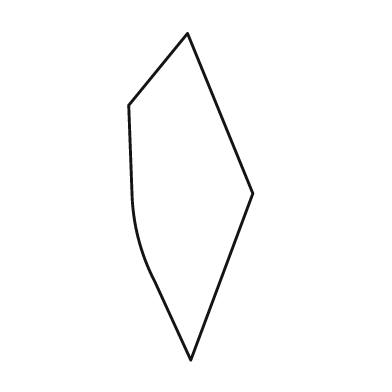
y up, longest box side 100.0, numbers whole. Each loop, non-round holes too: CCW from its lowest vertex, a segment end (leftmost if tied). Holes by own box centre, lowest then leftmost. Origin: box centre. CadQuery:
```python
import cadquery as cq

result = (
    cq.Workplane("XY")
    .moveTo(0.0, -50.0)
    .lineTo(19.0, 1.0)
    .lineTo(-1.0, 50.0)
    .lineTo(-19.0, 28.0)
    .lineTo(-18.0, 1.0)
    .threePointArc((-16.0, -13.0), (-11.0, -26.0))
    .close()
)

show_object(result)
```